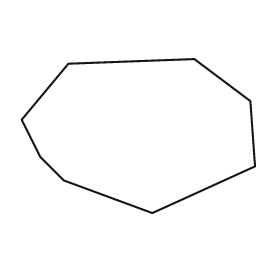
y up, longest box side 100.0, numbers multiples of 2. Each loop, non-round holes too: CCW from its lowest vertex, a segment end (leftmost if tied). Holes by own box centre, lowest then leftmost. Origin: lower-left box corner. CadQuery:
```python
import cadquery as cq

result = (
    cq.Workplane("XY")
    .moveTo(56.0, 0.0)
    .lineTo(100.0, 20.0)
    .lineTo(98.0, 48.0)
    .lineTo(74.0, 66.0)
    .lineTo(20.0, 64.0)
    .lineTo(0.0, 40.0)
    .lineTo(8.0, 24.0)
    .lineTo(18.0, 14.0)
    .close()
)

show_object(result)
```